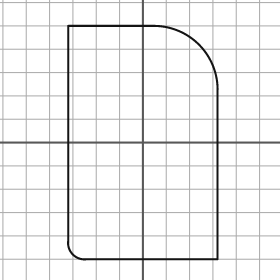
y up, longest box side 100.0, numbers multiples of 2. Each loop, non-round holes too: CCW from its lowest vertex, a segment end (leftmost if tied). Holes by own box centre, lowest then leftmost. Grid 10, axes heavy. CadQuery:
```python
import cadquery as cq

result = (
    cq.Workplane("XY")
    .moveTo(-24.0, -50.0)
    .lineTo(32.0, -50.0)
    .lineTo(32.0, 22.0)
    .threePointArc((24.0, 42.0), (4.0, 50.0))
    .lineTo(-32.0, 50.0)
    .lineTo(-32.0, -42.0)
    .threePointArc((-30.0, -48.0), (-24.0, -50.0))
    .close()
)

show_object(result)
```